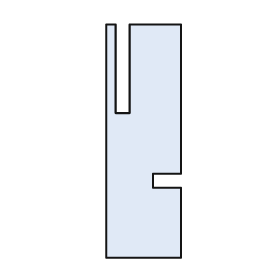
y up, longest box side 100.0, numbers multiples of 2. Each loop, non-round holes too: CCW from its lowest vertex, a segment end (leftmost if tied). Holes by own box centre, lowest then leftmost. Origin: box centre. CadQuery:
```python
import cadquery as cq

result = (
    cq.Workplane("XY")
    .moveTo(-16.0, -50.0)
    .lineTo(16.0, -50.0)
    .lineTo(16.0, -20.0)
    .lineTo(4.0, -20.0)
    .lineTo(4.0, -14.0)
    .lineTo(16.0, -14.0)
    .lineTo(16.0, 50.0)
    .lineTo(-6.0, 50.0)
    .lineTo(-6.0, 12.0)
    .lineTo(-12.0, 12.0)
    .lineTo(-12.0, 50.0)
    .lineTo(-16.0, 50.0)
    .close()
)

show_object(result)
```